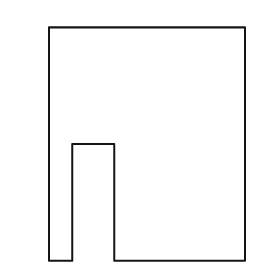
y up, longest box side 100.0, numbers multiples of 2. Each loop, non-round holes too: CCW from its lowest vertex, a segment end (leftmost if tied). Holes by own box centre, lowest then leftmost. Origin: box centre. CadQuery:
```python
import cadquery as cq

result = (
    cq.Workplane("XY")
    .moveTo(-42.0, -50.0)
    .lineTo(-32.0, -50.0)
    .lineTo(-32.0, 0.0)
    .lineTo(-14.0, 0.0)
    .lineTo(-14.0, -50.0)
    .lineTo(42.0, -50.0)
    .lineTo(42.0, 50.0)
    .lineTo(-42.0, 50.0)
    .close()
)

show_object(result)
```